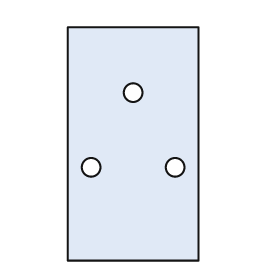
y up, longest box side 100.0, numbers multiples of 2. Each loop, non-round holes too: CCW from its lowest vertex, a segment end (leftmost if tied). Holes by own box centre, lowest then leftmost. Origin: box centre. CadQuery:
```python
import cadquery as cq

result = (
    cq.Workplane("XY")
    .moveTo(-28.0, -50.0)
    .lineTo(28.0, -50.0)
    .lineTo(28.0, 50.0)
    .lineTo(-28.0, 50.0)
    .close()
    .moveTo(-18.0, -10.0)
    .circle(4.0)
    .moveTo(18.0, -10.0)
    .circle(4.0)
    .moveTo(0.0, 22.0)
    .circle(4.0)
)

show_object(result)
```